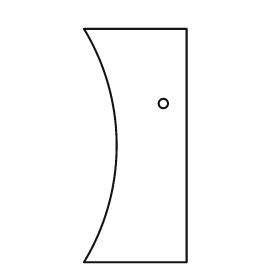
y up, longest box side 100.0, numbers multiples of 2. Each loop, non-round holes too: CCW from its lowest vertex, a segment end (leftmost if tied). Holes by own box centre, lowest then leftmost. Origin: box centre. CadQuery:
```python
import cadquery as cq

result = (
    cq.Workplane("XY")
    .moveTo(-22.0, -50.0)
    .lineTo(22.0, -50.0)
    .lineTo(22.0, 50.0)
    .lineTo(-22.0, 50.0)
    .threePointArc((-8.0, 0.0), (-22.0, -50.0))
    .close()
    .moveTo(12.0, 18.0)
    .circle(2.0)
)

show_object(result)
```